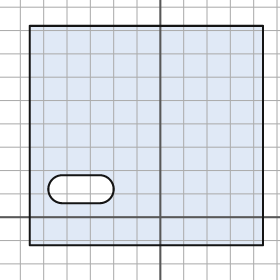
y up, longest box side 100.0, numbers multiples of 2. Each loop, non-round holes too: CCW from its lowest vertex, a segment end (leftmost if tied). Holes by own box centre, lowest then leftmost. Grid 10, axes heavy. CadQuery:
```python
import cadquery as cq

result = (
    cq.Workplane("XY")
    .moveTo(-56.0, -12.0)
    .lineTo(44.0, -12.0)
    .lineTo(44.0, 82.0)
    .lineTo(-56.0, 82.0)
    .close()
    .moveTo(-42.0, 6.0)
    .lineTo(-26.0, 6.0)
    .threePointArc((-20.0, 12.0), (-26.0, 18.0))
    .lineTo(-42.0, 18.0)
    .threePointArc((-48.0, 12.0), (-42.0, 6.0))
    .close()
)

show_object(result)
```